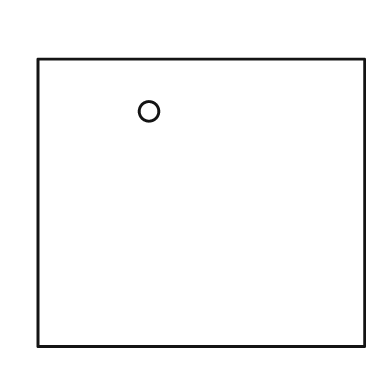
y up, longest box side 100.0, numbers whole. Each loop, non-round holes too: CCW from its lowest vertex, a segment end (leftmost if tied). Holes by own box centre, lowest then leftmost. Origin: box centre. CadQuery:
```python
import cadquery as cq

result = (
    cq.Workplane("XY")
    .moveTo(-50.0, -44.0)
    .lineTo(50.0, -44.0)
    .lineTo(50.0, 44.0)
    .lineTo(-50.0, 44.0)
    .close()
    .moveTo(-16.0, 28.0)
    .circle(3.0)
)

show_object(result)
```